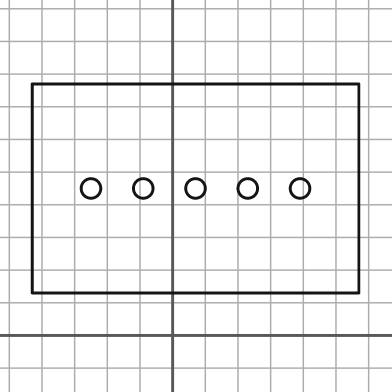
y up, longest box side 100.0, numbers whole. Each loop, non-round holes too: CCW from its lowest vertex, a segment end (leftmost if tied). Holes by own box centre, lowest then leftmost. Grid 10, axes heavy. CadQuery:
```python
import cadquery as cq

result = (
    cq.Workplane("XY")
    .moveTo(-43.0, 13.0)
    .lineTo(57.0, 13.0)
    .lineTo(57.0, 77.0)
    .lineTo(-43.0, 77.0)
    .close()
    .moveTo(-25.0, 45.0)
    .circle(3.0)
    .moveTo(-9.0, 45.0)
    .circle(3.0)
    .moveTo(7.0, 45.0)
    .circle(3.0)
    .moveTo(23.0, 45.0)
    .circle(3.0)
    .moveTo(39.0, 45.0)
    .circle(3.0)
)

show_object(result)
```